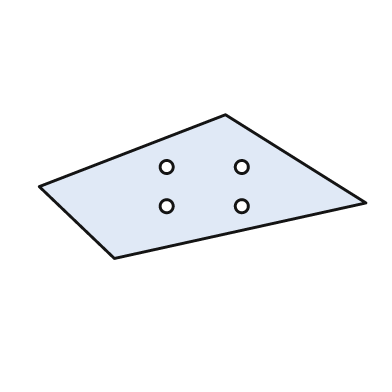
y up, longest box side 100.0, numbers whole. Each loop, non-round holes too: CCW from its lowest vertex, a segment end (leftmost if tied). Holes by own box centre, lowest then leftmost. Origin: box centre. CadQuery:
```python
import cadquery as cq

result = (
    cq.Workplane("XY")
    .moveTo(-27.0, -22.0)
    .lineTo(50.0, -5.0)
    .lineTo(7.0, 22.0)
    .lineTo(-50.0, 0.0)
    .close()
    .moveTo(-11.0, -6.0)
    .circle(2.0)
    .moveTo(12.0, -6.0)
    .circle(2.0)
    .moveTo(-11.0, 6.0)
    .circle(2.0)
    .moveTo(12.0, 6.0)
    .circle(2.0)
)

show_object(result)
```